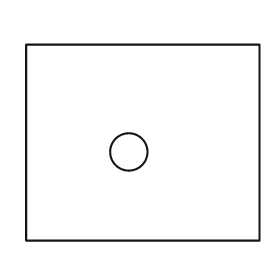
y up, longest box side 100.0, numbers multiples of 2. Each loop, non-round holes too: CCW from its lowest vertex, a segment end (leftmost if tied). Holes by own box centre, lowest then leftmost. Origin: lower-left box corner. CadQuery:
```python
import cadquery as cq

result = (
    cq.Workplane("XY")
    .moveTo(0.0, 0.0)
    .lineTo(100.0, 0.0)
    .lineTo(100.0, 84.0)
    .lineTo(0.0, 84.0)
    .close()
    .moveTo(44.0, 38.0)
    .circle(8.0)
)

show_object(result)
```